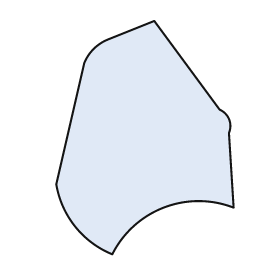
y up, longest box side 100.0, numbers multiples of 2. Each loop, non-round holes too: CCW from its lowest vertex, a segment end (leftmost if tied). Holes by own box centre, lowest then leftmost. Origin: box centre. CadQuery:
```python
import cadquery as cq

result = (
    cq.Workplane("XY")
    .moveTo(-14.0, -50.0)
    .threePointArc((8.0, -30.0), (38.0, -30.0))
    .lineTo(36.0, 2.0)
    .threePointArc((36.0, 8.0), (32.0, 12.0))
    .lineTo(4.0, 50.0)
    .lineTo(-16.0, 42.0)
    .threePointArc((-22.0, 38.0), (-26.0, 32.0))
    .lineTo(-38.0, -20.0)
    .threePointArc((-30.0, -38.0), (-14.0, -50.0))
    .close()
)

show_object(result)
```